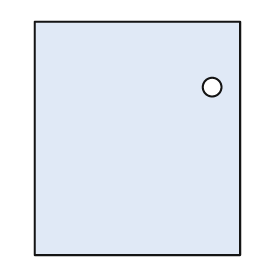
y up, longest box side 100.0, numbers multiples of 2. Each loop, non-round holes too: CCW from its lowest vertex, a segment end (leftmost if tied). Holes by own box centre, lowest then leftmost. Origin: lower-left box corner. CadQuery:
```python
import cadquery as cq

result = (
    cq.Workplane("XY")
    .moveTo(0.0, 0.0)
    .lineTo(88.0, 0.0)
    .lineTo(88.0, 100.0)
    .lineTo(0.0, 100.0)
    .close()
    .moveTo(76.0, 72.0)
    .circle(4.0)
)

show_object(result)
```